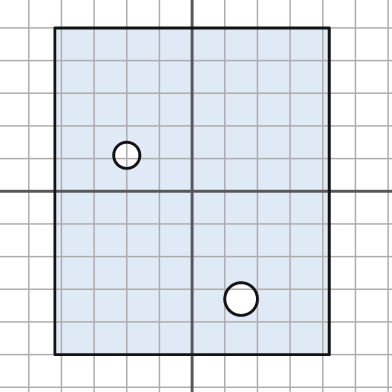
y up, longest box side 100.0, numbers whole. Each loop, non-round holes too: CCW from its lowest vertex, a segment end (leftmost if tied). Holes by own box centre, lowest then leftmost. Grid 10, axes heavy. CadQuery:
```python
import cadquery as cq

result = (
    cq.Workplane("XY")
    .moveTo(-42.0, -50.0)
    .lineTo(42.0, -50.0)
    .lineTo(42.0, 50.0)
    .lineTo(-42.0, 50.0)
    .close()
    .moveTo(15.0, -33.0)
    .circle(5.0)
    .moveTo(-20.0, 11.0)
    .circle(4.0)
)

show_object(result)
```